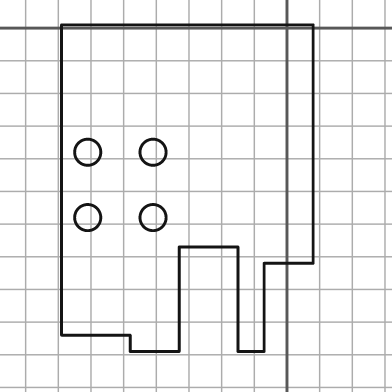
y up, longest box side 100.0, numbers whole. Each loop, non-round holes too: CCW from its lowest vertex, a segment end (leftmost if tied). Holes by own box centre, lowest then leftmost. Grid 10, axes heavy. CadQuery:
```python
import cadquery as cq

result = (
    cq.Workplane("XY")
    .moveTo(-48.0, -99.0)
    .lineTo(-33.0, -99.0)
    .lineTo(-33.0, -67.0)
    .lineTo(-15.0, -67.0)
    .lineTo(-15.0, -99.0)
    .lineTo(-7.0, -99.0)
    .lineTo(-7.0, -72.0)
    .lineTo(8.0, -72.0)
    .lineTo(8.0, 1.0)
    .lineTo(-69.0, 1.0)
    .lineTo(-69.0, -94.0)
    .lineTo(-48.0, -94.0)
    .close()
    .moveTo(-61.0, -58.0)
    .circle(4.0)
    .moveTo(-41.0, -58.0)
    .circle(4.0)
    .moveTo(-61.0, -38.0)
    .circle(4.0)
    .moveTo(-41.0, -38.0)
    .circle(4.0)
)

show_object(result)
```